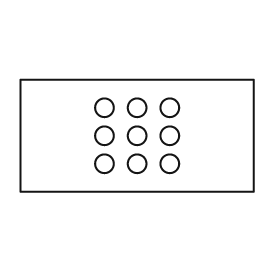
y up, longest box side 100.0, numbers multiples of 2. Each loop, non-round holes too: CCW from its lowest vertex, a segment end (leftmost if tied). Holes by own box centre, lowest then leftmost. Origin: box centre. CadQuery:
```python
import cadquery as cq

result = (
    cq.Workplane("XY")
    .moveTo(-50.0, -24.0)
    .lineTo(50.0, -24.0)
    .lineTo(50.0, 24.0)
    .lineTo(-50.0, 24.0)
    .close()
    .moveTo(-14.0, -12.0)
    .circle(4.0)
    .moveTo(0.0, -12.0)
    .circle(4.0)
    .moveTo(14.0, -12.0)
    .circle(4.0)
    .moveTo(-14.0, 0.0)
    .circle(4.0)
    .moveTo(0.0, 0.0)
    .circle(4.0)
    .moveTo(14.0, 0.0)
    .circle(4.0)
    .moveTo(-14.0, 12.0)
    .circle(4.0)
    .moveTo(0.0, 12.0)
    .circle(4.0)
    .moveTo(14.0, 12.0)
    .circle(4.0)
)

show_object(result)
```